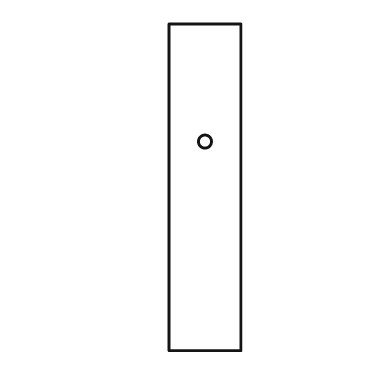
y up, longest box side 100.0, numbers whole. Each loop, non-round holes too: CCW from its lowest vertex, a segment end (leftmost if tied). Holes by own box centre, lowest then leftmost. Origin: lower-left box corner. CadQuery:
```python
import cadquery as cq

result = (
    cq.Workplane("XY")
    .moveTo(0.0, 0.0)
    .lineTo(22.0, 0.0)
    .lineTo(22.0, 100.0)
    .lineTo(0.0, 100.0)
    .close()
    .moveTo(11.0, 64.0)
    .circle(2.0)
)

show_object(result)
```